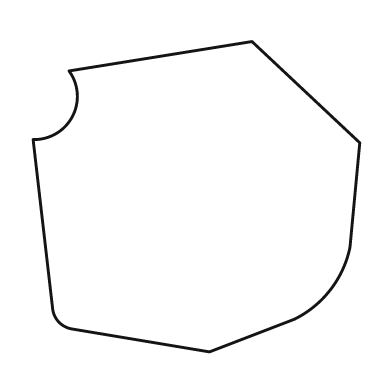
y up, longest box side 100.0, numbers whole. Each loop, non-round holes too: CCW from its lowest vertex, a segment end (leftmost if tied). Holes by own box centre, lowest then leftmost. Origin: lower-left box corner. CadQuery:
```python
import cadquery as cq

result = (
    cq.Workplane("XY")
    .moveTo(54.0, 0.0)
    .lineTo(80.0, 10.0)
    .threePointArc((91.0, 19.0), (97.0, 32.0))
    .lineTo(100.0, 64.0)
    .lineTo(67.0, 95.0)
    .lineTo(11.0, 86.0)
    .threePointArc((12.0, 72.0), (0.0, 65.0))
    .lineTo(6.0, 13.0)
    .threePointArc((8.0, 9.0), (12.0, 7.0))
    .close()
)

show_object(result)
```